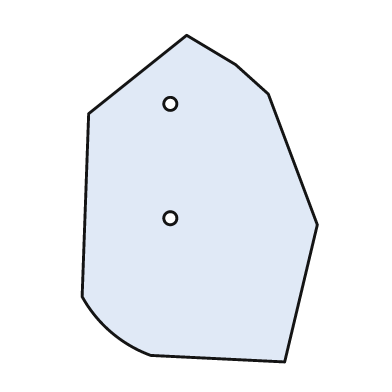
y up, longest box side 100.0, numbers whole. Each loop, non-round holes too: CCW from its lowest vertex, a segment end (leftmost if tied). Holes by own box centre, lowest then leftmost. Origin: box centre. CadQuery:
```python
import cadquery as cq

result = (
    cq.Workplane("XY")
    .moveTo(26.0, -50.0)
    .lineTo(36.0, -8.0)
    .lineTo(21.0, 32.0)
    .lineTo(11.0, 41.0)
    .lineTo(-4.0, 50.0)
    .lineTo(-34.0, 26.0)
    .lineTo(-36.0, -30.0)
    .threePointArc((-27.0, -41.0), (-15.0, -48.0))
    .close()
    .moveTo(-9.0, -6.0)
    .circle(2.0)
    .moveTo(-9.0, 29.0)
    .circle(2.0)
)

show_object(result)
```